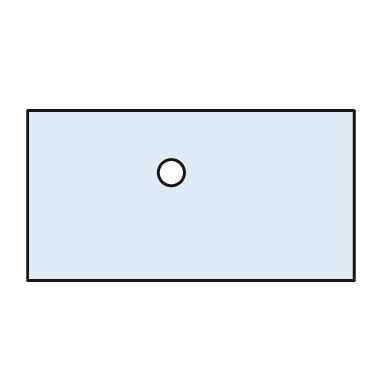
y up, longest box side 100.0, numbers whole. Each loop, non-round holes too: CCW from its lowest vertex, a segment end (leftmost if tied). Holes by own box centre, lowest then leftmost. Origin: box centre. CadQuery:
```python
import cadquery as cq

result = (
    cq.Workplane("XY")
    .moveTo(-50.0, -26.0)
    .lineTo(50.0, -26.0)
    .lineTo(50.0, 26.0)
    .lineTo(-50.0, 26.0)
    .close()
    .moveTo(-6.0, 7.0)
    .circle(4.0)
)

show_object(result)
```